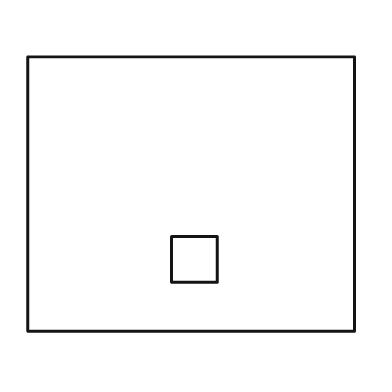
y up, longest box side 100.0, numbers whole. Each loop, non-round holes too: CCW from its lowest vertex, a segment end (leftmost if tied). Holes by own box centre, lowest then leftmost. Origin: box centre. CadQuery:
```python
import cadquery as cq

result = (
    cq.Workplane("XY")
    .moveTo(-50.0, -42.0)
    .lineTo(50.0, -42.0)
    .lineTo(50.0, 42.0)
    .lineTo(-50.0, 42.0)
    .close()
    .moveTo(-6.0, -27.0)
    .lineTo(8.0, -27.0)
    .lineTo(8.0, -13.0)
    .lineTo(-6.0, -13.0)
    .close()
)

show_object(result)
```